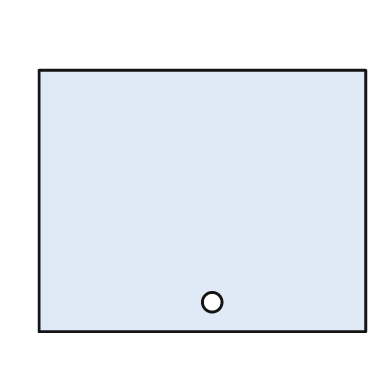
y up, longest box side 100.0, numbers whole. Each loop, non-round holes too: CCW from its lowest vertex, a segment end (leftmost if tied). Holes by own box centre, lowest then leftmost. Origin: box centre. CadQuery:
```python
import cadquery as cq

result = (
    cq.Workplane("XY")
    .moveTo(-50.0, -40.0)
    .lineTo(50.0, -40.0)
    .lineTo(50.0, 40.0)
    .lineTo(-50.0, 40.0)
    .close()
    .moveTo(3.0, -31.0)
    .circle(3.0)
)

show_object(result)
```